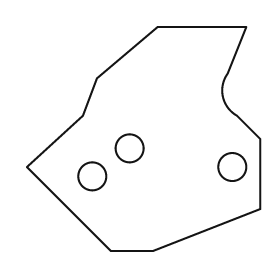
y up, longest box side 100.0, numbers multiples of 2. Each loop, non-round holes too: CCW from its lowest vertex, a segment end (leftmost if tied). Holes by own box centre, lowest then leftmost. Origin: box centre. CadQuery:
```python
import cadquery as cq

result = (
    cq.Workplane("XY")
    .moveTo(-14.0, -48.0)
    .lineTo(4.0, -48.0)
    .lineTo(50.0, -30.0)
    .lineTo(50.0, 0.0)
    .lineTo(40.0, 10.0)
    .threePointArc((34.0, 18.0), (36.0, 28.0))
    .lineTo(44.0, 48.0)
    .lineTo(6.0, 48.0)
    .lineTo(-20.0, 26.0)
    .lineTo(-26.0, 10.0)
    .lineTo(-50.0, -12.0)
    .close()
    .moveTo(-22.0, -16.0)
    .circle(6.0)
    .moveTo(38.0, -12.0)
    .circle(6.0)
    .moveTo(-6.0, -4.0)
    .circle(6.0)
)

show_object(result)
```